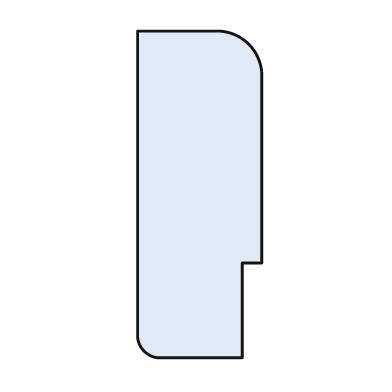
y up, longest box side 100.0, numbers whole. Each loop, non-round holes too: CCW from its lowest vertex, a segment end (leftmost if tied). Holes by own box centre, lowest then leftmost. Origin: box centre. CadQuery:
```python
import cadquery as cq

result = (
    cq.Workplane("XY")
    .moveTo(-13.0, -50.0)
    .lineTo(13.0, -50.0)
    .lineTo(13.0, -21.0)
    .lineTo(19.0, -21.0)
    .lineTo(19.0, 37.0)
    .threePointArc((15.0, 46.0), (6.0, 50.0))
    .lineTo(-19.0, 50.0)
    .lineTo(-19.0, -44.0)
    .threePointArc((-17.0, -48.0), (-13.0, -50.0))
    .close()
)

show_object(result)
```